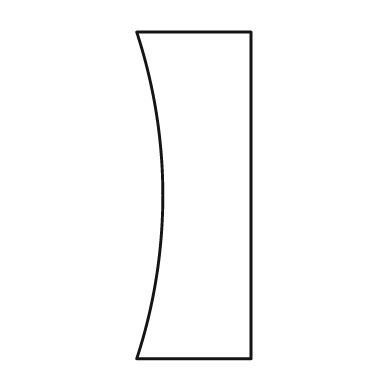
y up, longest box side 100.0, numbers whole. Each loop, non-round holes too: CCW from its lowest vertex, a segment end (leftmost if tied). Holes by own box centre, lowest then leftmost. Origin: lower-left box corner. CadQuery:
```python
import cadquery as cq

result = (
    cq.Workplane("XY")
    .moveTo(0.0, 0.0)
    .lineTo(35.0, 0.0)
    .lineTo(35.0, 100.0)
    .lineTo(0.0, 100.0)
    .threePointArc((8.0, 50.0), (0.0, 0.0))
    .close()
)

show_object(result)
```